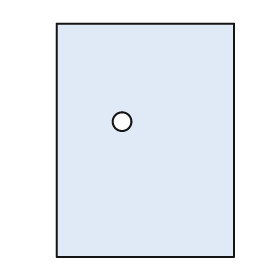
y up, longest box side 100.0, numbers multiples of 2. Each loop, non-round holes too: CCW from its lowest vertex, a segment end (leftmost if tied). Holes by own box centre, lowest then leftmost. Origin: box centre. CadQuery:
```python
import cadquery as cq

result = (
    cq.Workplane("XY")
    .moveTo(-38.0, -50.0)
    .lineTo(38.0, -50.0)
    .lineTo(38.0, 50.0)
    .lineTo(-38.0, 50.0)
    .close()
    .moveTo(-10.0, 8.0)
    .circle(4.0)
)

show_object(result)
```